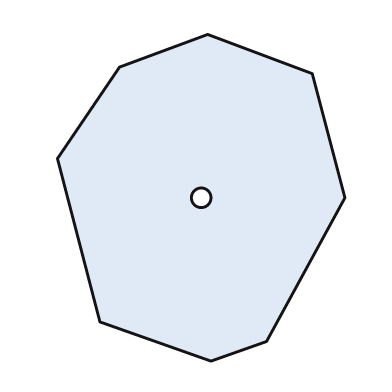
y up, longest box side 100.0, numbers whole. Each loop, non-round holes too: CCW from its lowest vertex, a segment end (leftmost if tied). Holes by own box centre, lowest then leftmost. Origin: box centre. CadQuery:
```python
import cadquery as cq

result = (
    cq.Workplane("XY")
    .moveTo(3.0, -50.0)
    .lineTo(20.0, -44.0)
    .lineTo(44.0, 0.0)
    .lineTo(34.0, 38.0)
    .lineTo(2.0, 50.0)
    .lineTo(-25.0, 40.0)
    .lineTo(-44.0, 12.0)
    .lineTo(-31.0, -38.0)
    .close()
    .moveTo(0.0, 0.0)
    .circle(3.0)
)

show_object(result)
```